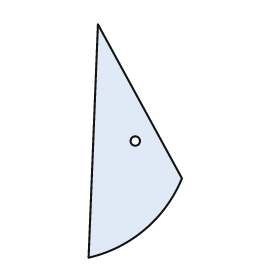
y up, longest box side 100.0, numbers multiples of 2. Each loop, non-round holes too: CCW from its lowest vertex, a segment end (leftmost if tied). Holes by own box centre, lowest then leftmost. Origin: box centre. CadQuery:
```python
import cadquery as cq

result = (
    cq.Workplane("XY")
    .moveTo(-20.0, -50.0)
    .threePointArc((4.0, -38.0), (20.0, -16.0))
    .lineTo(-16.0, 50.0)
    .close()
    .moveTo(0.0, 0.0)
    .circle(2.0)
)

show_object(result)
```